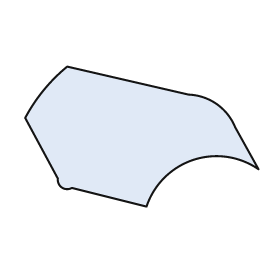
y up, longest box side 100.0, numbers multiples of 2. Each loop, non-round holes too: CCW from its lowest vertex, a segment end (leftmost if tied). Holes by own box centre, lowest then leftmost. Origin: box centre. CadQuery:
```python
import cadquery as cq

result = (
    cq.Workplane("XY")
    .moveTo(2.0, -30.0)
    .threePointArc((22.0, -10.0), (50.0, -14.0))
    .lineTo(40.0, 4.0)
    .threePointArc((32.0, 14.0), (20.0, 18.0))
    .lineTo(-32.0, 30.0)
    .threePointArc((-42.0, 20.0), (-50.0, 8.0))
    .lineTo(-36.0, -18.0)
    .threePointArc((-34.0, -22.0), (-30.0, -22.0))
    .close()
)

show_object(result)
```